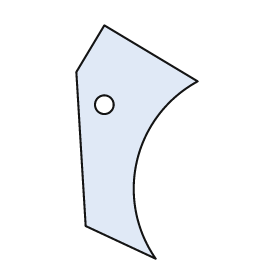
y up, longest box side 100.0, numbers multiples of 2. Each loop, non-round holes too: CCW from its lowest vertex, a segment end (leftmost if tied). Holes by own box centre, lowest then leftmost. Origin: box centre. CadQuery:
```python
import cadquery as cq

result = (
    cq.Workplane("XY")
    .moveTo(8.0, -50.0)
    .threePointArc((0.0, -8.0), (26.0, 26.0))
    .lineTo(-14.0, 50.0)
    .lineTo(-26.0, 30.0)
    .lineTo(-22.0, -36.0)
    .close()
    .moveTo(-14.0, 16.0)
    .circle(4.0)
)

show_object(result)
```